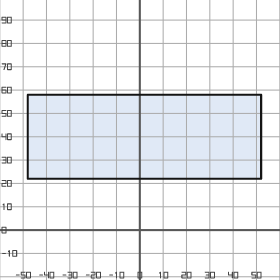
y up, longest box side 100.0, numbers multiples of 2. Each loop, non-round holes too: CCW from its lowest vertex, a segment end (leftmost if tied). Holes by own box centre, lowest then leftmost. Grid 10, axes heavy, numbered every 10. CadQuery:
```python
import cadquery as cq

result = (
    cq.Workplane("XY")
    .moveTo(-48.0, 22.0)
    .lineTo(52.0, 22.0)
    .lineTo(52.0, 58.0)
    .lineTo(-48.0, 58.0)
    .close()
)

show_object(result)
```